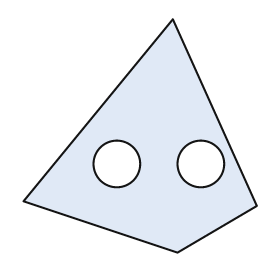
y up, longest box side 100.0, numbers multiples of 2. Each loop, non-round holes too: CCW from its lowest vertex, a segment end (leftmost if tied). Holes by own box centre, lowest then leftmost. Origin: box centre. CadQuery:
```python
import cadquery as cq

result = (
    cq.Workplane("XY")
    .moveTo(16.0, -50.0)
    .lineTo(50.0, -30.0)
    .lineTo(14.0, 50.0)
    .lineTo(-50.0, -28.0)
    .close()
    .moveTo(-10.0, -12.0)
    .circle(10.0)
    .moveTo(26.0, -12.0)
    .circle(10.0)
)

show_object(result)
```